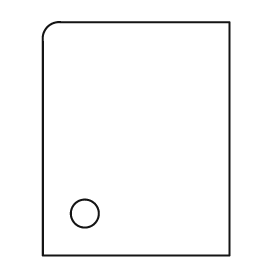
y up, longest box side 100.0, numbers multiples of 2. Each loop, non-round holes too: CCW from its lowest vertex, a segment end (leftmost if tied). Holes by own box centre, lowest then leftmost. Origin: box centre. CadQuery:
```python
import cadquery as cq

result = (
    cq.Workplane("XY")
    .moveTo(-40.0, -50.0)
    .lineTo(40.0, -50.0)
    .lineTo(40.0, 50.0)
    .lineTo(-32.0, 50.0)
    .threePointArc((-38.0, 48.0), (-40.0, 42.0))
    .close()
    .moveTo(-22.0, -32.0)
    .circle(6.0)
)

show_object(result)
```